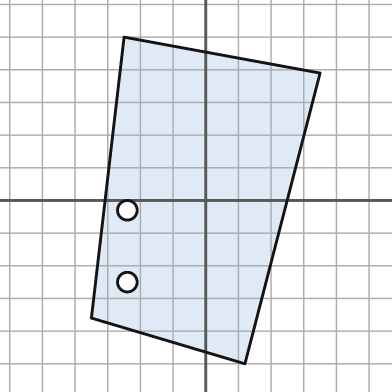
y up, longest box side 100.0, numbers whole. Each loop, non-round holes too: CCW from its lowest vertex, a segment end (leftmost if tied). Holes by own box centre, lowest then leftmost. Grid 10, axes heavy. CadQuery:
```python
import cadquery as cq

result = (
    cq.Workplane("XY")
    .moveTo(12.0, -50.0)
    .lineTo(35.0, 39.0)
    .lineTo(-25.0, 50.0)
    .lineTo(-35.0, -36.0)
    .close()
    .moveTo(-24.0, -25.0)
    .circle(3.0)
    .moveTo(-24.0, -3.0)
    .circle(3.0)
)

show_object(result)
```